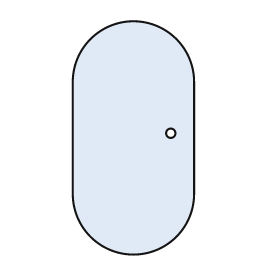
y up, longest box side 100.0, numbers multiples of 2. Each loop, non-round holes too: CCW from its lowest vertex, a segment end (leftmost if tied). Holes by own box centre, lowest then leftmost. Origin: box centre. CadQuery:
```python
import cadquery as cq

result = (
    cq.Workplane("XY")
    .moveTo(-26.0, -24.0)
    .threePointArc((0.0, -50.0), (26.0, -24.0))
    .lineTo(26.0, 24.0)
    .threePointArc((0.0, 50.0), (-26.0, 24.0))
    .close()
    .moveTo(16.0, 2.0)
    .circle(2.0)
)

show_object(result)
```